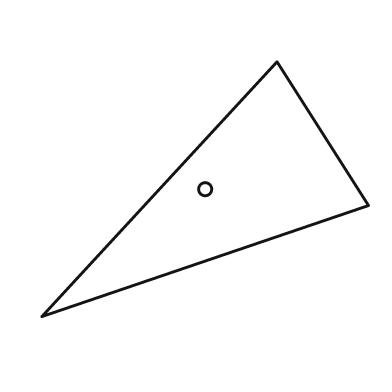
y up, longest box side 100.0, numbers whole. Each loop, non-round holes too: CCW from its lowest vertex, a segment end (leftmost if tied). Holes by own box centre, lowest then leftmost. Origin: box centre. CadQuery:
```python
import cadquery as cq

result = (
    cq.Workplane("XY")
    .moveTo(-50.0, -39.0)
    .lineTo(50.0, -5.0)
    .lineTo(22.0, 39.0)
    .close()
    .moveTo(0.0, 0.0)
    .circle(2.0)
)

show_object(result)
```